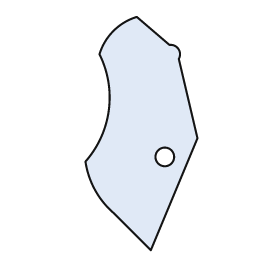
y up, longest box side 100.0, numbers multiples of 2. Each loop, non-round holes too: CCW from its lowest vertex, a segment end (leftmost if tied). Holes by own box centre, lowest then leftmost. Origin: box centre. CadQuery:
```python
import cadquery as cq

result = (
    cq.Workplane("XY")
    .moveTo(4.0, -50.0)
    .lineTo(24.0, -2.0)
    .lineTo(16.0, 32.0)
    .threePointArc((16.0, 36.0), (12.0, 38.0))
    .lineTo(-2.0, 50.0)
    .threePointArc((-12.0, 44.0), (-18.0, 34.0))
    .threePointArc((-14.0, 10.0), (-24.0, -12.0))
    .threePointArc((-20.0, -24.0), (-12.0, -34.0))
    .close()
    .moveTo(10.0, -10.0)
    .circle(4.0)
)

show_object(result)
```